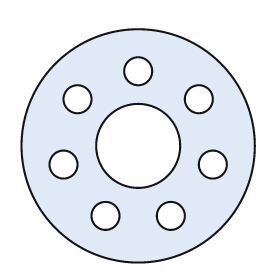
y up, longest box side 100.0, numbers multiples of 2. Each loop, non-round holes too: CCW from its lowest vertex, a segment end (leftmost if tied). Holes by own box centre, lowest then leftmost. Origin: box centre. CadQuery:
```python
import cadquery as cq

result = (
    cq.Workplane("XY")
    .moveTo(0.0, 0.0)
    .circle(50.0)
    .moveTo(-14.0, -30.0)
    .circle(6.0)
    .moveTo(14.0, -30.0)
    .circle(6.0)
    .moveTo(-32.0, -8.0)
    .circle(6.0)
    .moveTo(32.0, -8.0)
    .circle(6.0)
    .moveTo(0.0, 0.0)
    .circle(18.0)
    .moveTo(-26.0, 20.0)
    .circle(6.0)
    .moveTo(26.0, 20.0)
    .circle(6.0)
    .moveTo(0.0, 32.0)
    .circle(6.0)
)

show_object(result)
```